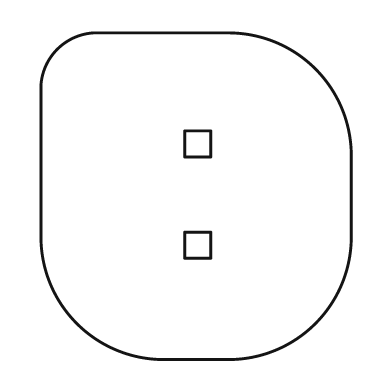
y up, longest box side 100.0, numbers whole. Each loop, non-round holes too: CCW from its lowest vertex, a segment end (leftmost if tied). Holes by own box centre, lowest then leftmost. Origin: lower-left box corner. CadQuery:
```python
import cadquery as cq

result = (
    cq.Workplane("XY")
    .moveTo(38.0, 0.0)
    .lineTo(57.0, 0.0)
    .threePointArc((84.0, 11.0), (95.0, 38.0))
    .lineTo(95.0, 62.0)
    .threePointArc((84.0, 89.0), (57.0, 100.0))
    .lineTo(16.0, 100.0)
    .threePointArc((5.0, 95.0), (0.0, 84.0))
    .lineTo(0.0, 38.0)
    .threePointArc((11.0, 11.0), (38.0, 0.0))
    .close()
    .moveTo(44.0, 31.0)
    .lineTo(52.0, 31.0)
    .lineTo(52.0, 39.0)
    .lineTo(44.0, 39.0)
    .close()
    .moveTo(44.0, 62.0)
    .lineTo(52.0, 62.0)
    .lineTo(52.0, 70.0)
    .lineTo(44.0, 70.0)
    .close()
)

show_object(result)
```